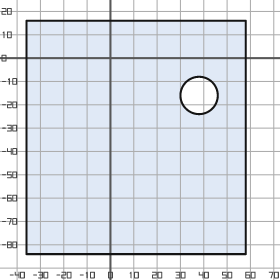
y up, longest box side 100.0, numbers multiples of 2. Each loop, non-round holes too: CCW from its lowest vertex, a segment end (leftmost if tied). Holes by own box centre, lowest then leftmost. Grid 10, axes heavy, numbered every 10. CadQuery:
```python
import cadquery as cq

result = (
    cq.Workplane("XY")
    .moveTo(-36.0, -84.0)
    .lineTo(58.0, -84.0)
    .lineTo(58.0, 16.0)
    .lineTo(-36.0, 16.0)
    .close()
    .moveTo(38.0, -16.0)
    .circle(8.0)
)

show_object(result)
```